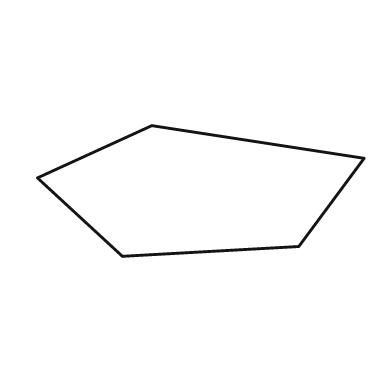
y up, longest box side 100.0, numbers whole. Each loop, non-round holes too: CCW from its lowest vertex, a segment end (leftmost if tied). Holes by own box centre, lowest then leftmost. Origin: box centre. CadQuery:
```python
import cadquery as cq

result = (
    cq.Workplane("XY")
    .moveTo(-24.0, -20.0)
    .lineTo(30.0, -17.0)
    .lineTo(50.0, 10.0)
    .lineTo(-15.0, 20.0)
    .lineTo(-50.0, 4.0)
    .close()
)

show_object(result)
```